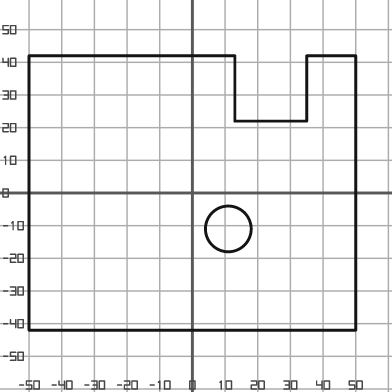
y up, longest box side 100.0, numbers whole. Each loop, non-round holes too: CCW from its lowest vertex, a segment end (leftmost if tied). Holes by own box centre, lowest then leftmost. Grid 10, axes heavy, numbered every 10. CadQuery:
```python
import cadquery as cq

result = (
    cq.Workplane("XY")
    .moveTo(-50.0, -42.0)
    .lineTo(50.0, -42.0)
    .lineTo(50.0, 42.0)
    .lineTo(35.0, 42.0)
    .lineTo(35.0, 22.0)
    .lineTo(13.0, 22.0)
    .lineTo(13.0, 42.0)
    .lineTo(-50.0, 42.0)
    .close()
    .moveTo(11.0, -11.0)
    .circle(7.0)
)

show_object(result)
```